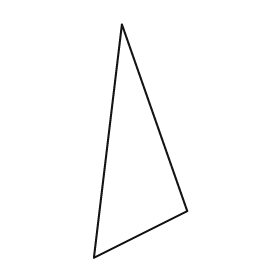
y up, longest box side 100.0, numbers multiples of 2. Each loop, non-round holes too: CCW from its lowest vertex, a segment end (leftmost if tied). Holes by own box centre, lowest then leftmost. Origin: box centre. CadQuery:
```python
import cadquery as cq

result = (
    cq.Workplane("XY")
    .moveTo(-20.0, -50.0)
    .lineTo(20.0, -30.0)
    .lineTo(-8.0, 50.0)
    .close()
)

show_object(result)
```